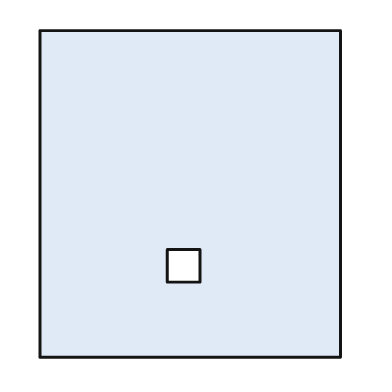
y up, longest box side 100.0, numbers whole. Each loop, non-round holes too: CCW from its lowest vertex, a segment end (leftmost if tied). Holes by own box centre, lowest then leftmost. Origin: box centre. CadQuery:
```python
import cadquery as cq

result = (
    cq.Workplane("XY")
    .moveTo(-46.0, -50.0)
    .lineTo(46.0, -50.0)
    .lineTo(46.0, 50.0)
    .lineTo(-46.0, 50.0)
    .close()
    .moveTo(-7.0, -27.0)
    .lineTo(3.0, -27.0)
    .lineTo(3.0, -17.0)
    .lineTo(-7.0, -17.0)
    .close()
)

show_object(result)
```